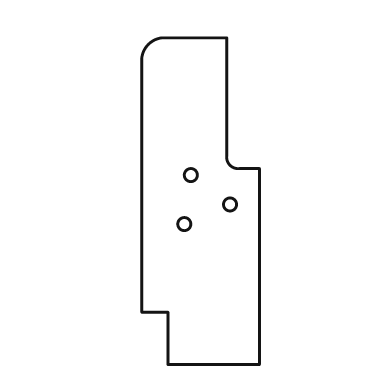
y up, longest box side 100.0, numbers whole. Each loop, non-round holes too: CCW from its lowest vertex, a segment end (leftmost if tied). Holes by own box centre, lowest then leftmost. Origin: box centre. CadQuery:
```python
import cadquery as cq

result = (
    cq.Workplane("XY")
    .moveTo(-10.0, -50.0)
    .lineTo(18.0, -50.0)
    .lineTo(18.0, 10.0)
    .lineTo(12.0, 10.0)
    .threePointArc((9.0, 11.0), (8.0, 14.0))
    .lineTo(8.0, 50.0)
    .lineTo(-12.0, 50.0)
    .threePointArc((-16.0, 48.0), (-18.0, 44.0))
    .lineTo(-18.0, -34.0)
    .lineTo(-10.0, -34.0)
    .close()
    .moveTo(-5.0, -7.0)
    .circle(2.0)
    .moveTo(9.0, -1.0)
    .circle(2.0)
    .moveTo(-3.0, 8.0)
    .circle(2.0)
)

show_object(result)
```